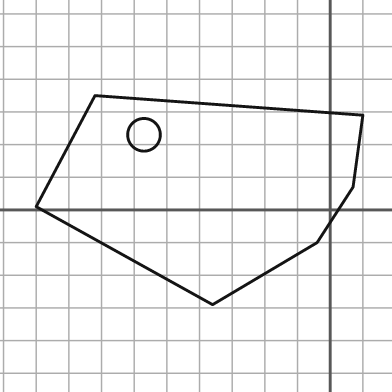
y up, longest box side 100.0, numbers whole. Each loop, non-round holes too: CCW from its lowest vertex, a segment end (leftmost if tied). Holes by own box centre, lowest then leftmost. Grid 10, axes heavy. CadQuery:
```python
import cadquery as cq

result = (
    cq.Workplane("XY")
    .moveTo(-36.0, -29.0)
    .lineTo(-4.0, -10.0)
    .lineTo(7.0, 7.0)
    .lineTo(10.0, 29.0)
    .lineTo(-72.0, 35.0)
    .lineTo(-90.0, 1.0)
    .close()
    .moveTo(-57.0, 23.0)
    .circle(5.0)
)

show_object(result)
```